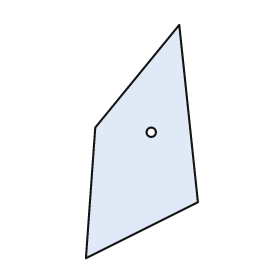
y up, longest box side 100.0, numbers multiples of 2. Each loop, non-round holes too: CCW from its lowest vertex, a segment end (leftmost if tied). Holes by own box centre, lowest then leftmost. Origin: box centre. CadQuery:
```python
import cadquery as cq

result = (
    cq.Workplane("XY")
    .moveTo(-24.0, -50.0)
    .lineTo(24.0, -26.0)
    .lineTo(16.0, 50.0)
    .lineTo(-20.0, 6.0)
    .close()
    .moveTo(4.0, 4.0)
    .circle(2.0)
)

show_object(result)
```